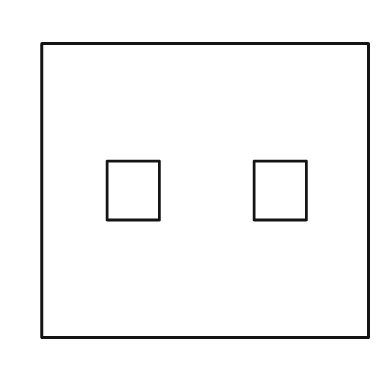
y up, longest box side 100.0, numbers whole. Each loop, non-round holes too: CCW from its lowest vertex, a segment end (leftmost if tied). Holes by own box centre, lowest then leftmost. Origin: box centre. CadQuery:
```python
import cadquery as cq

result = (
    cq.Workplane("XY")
    .moveTo(-50.0, -45.0)
    .lineTo(50.0, -45.0)
    .lineTo(50.0, 45.0)
    .lineTo(-50.0, 45.0)
    .close()
    .moveTo(-30.0, -9.0)
    .lineTo(-14.0, -9.0)
    .lineTo(-14.0, 9.0)
    .lineTo(-30.0, 9.0)
    .close()
    .moveTo(15.0, -9.0)
    .lineTo(31.0, -9.0)
    .lineTo(31.0, 9.0)
    .lineTo(15.0, 9.0)
    .close()
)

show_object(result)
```